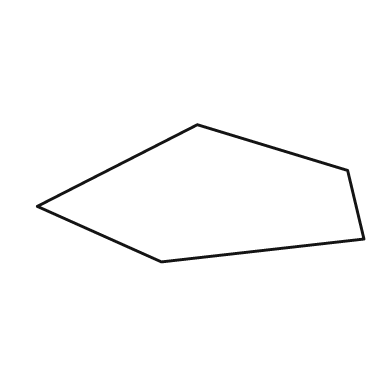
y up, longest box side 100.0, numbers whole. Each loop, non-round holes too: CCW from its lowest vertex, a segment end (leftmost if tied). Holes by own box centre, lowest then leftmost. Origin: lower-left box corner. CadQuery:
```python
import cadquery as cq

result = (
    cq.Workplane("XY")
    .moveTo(38.0, 0.0)
    .lineTo(100.0, 7.0)
    .lineTo(95.0, 28.0)
    .lineTo(49.0, 42.0)
    .lineTo(0.0, 17.0)
    .close()
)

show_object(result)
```